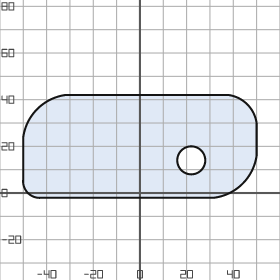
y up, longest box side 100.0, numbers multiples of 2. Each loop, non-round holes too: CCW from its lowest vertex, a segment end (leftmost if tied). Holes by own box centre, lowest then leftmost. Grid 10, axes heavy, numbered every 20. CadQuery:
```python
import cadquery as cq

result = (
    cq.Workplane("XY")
    .moveTo(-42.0, -2.0)
    .lineTo(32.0, -2.0)
    .threePointArc((44.0, 4.0), (50.0, 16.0))
    .lineTo(50.0, 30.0)
    .threePointArc((46.0, 38.0), (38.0, 42.0))
    .lineTo(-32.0, 42.0)
    .threePointArc((-44.0, 36.0), (-50.0, 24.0))
    .lineTo(-50.0, 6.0)
    .threePointArc((-48.0, 0.0), (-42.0, -2.0))
    .close()
    .moveTo(22.0, 14.0)
    .circle(6.0)
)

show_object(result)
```